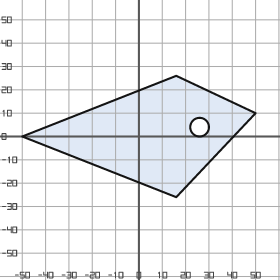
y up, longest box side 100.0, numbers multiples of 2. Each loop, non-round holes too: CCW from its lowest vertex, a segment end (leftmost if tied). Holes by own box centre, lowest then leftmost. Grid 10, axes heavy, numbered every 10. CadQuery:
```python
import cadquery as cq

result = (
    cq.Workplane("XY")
    .moveTo(16.0, -26.0)
    .lineTo(50.0, 10.0)
    .lineTo(16.0, 26.0)
    .lineTo(-50.0, 0.0)
    .close()
    .moveTo(26.0, 4.0)
    .circle(4.0)
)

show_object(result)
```